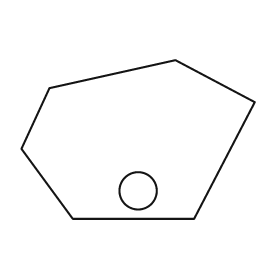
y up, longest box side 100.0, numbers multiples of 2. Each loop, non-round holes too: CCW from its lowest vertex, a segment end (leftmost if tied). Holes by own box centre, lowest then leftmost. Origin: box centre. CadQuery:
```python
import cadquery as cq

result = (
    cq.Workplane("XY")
    .moveTo(-28.0, -34.0)
    .lineTo(24.0, -34.0)
    .lineTo(50.0, 16.0)
    .lineTo(16.0, 34.0)
    .lineTo(-38.0, 22.0)
    .lineTo(-50.0, -4.0)
    .close()
    .moveTo(0.0, -22.0)
    .circle(8.0)
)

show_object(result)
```